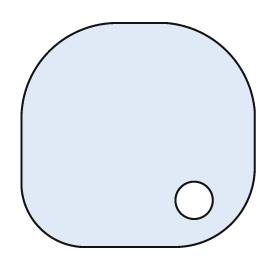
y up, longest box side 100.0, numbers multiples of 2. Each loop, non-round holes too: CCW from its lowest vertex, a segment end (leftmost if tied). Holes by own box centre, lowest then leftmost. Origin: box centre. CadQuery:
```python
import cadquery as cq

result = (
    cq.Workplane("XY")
    .moveTo(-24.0, -48.0)
    .lineTo(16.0, -48.0)
    .threePointArc((40.0, -38.0), (50.0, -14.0))
    .lineTo(50.0, 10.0)
    .threePointArc((38.0, 36.0), (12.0, 48.0))
    .lineTo(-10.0, 48.0)
    .threePointArc((-38.0, 36.0), (-50.0, 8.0))
    .lineTo(-50.0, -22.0)
    .threePointArc((-42.0, -40.0), (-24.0, -48.0))
    .close()
    .moveTo(24.0, -28.0)
    .circle(8.0)
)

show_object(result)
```